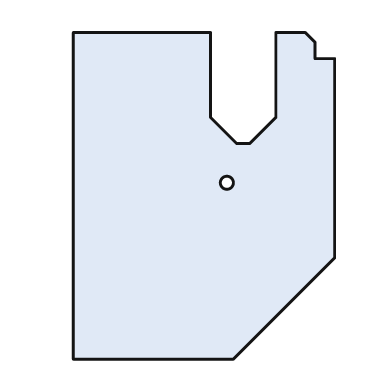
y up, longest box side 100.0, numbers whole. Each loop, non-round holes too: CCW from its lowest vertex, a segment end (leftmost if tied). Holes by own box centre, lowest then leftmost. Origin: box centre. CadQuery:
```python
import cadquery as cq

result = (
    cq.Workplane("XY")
    .moveTo(-40.0, -50.0)
    .lineTo(9.0, -50.0)
    .lineTo(40.0, -19.0)
    .lineTo(40.0, 42.0)
    .lineTo(34.0, 42.0)
    .lineTo(34.0, 47.0)
    .lineTo(31.0, 50.0)
    .lineTo(22.0, 50.0)
    .lineTo(22.0, 24.0)
    .lineTo(14.0, 16.0)
    .lineTo(10.0, 16.0)
    .lineTo(2.0, 24.0)
    .lineTo(2.0, 50.0)
    .lineTo(-40.0, 50.0)
    .close()
    .moveTo(7.0, 4.0)
    .circle(2.0)
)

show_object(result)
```